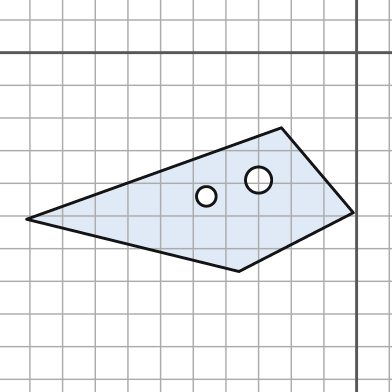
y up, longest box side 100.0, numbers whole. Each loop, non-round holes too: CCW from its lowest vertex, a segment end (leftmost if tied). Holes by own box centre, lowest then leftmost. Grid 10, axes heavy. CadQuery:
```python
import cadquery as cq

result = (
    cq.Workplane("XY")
    .moveTo(-36.0, -67.0)
    .lineTo(-1.0, -49.0)
    .lineTo(-23.0, -23.0)
    .lineTo(-101.0, -51.0)
    .close()
    .moveTo(-46.0, -44.0)
    .circle(3.0)
    .moveTo(-30.0, -39.0)
    .circle(4.0)
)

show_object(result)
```